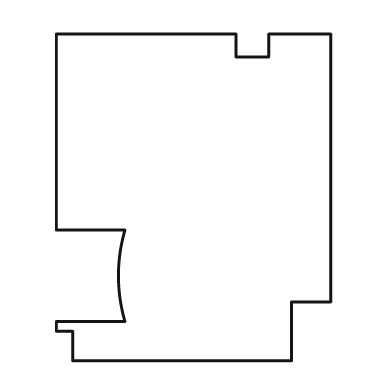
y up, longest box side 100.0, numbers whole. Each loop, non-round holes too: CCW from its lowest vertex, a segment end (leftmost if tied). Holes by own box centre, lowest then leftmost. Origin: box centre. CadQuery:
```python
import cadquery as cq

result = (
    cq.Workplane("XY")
    .moveTo(-37.0, -50.0)
    .lineTo(30.0, -50.0)
    .lineTo(30.0, -32.0)
    .lineTo(42.0, -32.0)
    .lineTo(42.0, 50.0)
    .lineTo(23.0, 50.0)
    .lineTo(23.0, 43.0)
    .lineTo(13.0, 43.0)
    .lineTo(13.0, 50.0)
    .lineTo(-42.0, 50.0)
    .lineTo(-42.0, -10.0)
    .lineTo(-21.0, -10.0)
    .threePointArc((-23.0, -24.0), (-21.0, -38.0))
    .lineTo(-42.0, -38.0)
    .lineTo(-42.0, -41.0)
    .lineTo(-37.0, -41.0)
    .close()
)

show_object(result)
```